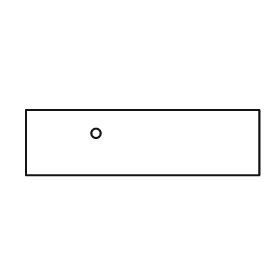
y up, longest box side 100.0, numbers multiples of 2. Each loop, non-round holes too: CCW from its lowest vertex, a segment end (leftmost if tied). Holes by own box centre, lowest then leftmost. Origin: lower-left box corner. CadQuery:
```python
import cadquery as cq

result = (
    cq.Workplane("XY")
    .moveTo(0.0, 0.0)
    .lineTo(100.0, 0.0)
    .lineTo(100.0, 28.0)
    .lineTo(0.0, 28.0)
    .close()
    .moveTo(30.0, 18.0)
    .circle(2.0)
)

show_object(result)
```